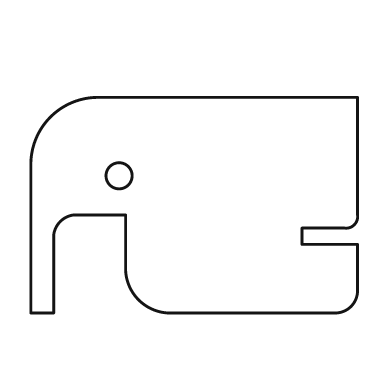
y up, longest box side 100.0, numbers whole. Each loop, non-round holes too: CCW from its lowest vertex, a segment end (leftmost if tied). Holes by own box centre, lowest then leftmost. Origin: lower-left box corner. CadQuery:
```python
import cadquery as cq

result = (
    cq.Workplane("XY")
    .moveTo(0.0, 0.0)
    .lineTo(7.0, 0.0)
    .lineTo(7.0, 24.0)
    .threePointArc((9.0, 28.0), (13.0, 30.0))
    .lineTo(29.0, 30.0)
    .lineTo(29.0, 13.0)
    .threePointArc((33.0, 4.0), (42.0, 0.0))
    .lineTo(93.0, 0.0)
    .threePointArc((98.0, 2.0), (100.0, 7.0))
    .lineTo(100.0, 21.0)
    .lineTo(83.0, 21.0)
    .lineTo(83.0, 26.0)
    .lineTo(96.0, 26.0)
    .threePointArc((99.0, 27.0), (100.0, 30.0))
    .lineTo(100.0, 66.0)
    .lineTo(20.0, 66.0)
    .threePointArc((6.0, 60.0), (0.0, 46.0))
    .close()
    .moveTo(27.0, 42.0)
    .circle(4.0)
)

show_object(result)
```